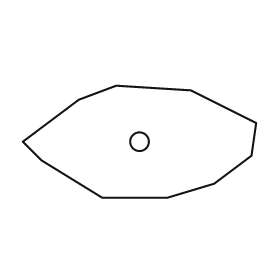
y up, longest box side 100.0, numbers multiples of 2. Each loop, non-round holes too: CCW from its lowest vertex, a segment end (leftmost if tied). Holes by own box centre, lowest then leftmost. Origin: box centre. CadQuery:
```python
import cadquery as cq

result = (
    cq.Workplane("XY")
    .moveTo(-16.0, -24.0)
    .lineTo(12.0, -24.0)
    .lineTo(32.0, -18.0)
    .lineTo(48.0, -6.0)
    .lineTo(50.0, 8.0)
    .lineTo(22.0, 22.0)
    .lineTo(-10.0, 24.0)
    .lineTo(-26.0, 18.0)
    .lineTo(-50.0, 0.0)
    .lineTo(-42.0, -8.0)
    .close()
    .moveTo(0.0, 0.0)
    .circle(4.0)
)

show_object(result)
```